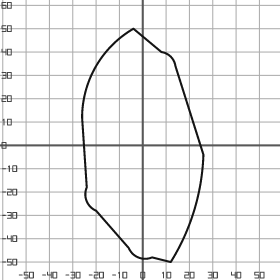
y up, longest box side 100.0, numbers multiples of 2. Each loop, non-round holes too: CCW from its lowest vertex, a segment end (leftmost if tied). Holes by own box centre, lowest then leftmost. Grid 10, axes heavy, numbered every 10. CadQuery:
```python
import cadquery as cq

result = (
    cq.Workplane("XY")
    .moveTo(12.0, -50.0)
    .threePointArc((22.0, -28.0), (26.0, -4.0))
    .lineTo(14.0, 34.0)
    .threePointArc((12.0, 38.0), (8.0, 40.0))
    .lineTo(-4.0, 50.0)
    .threePointArc((-20.0, 34.0), (-26.0, 12.0))
    .lineTo(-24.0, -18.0)
    .threePointArc((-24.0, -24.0), (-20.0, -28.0))
    .lineTo(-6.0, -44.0)
    .threePointArc((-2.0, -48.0), (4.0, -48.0))
    .close()
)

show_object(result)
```